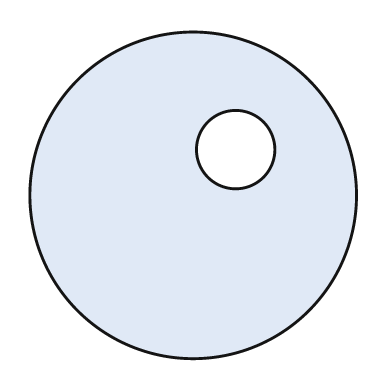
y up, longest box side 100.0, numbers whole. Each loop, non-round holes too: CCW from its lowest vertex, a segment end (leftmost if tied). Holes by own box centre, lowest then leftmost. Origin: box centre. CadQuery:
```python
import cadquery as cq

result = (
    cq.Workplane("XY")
    .moveTo(0.0, 0.0)
    .circle(50.0)
    .moveTo(13.0, 14.0)
    .circle(12.0)
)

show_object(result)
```